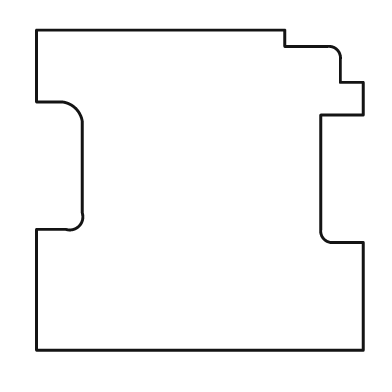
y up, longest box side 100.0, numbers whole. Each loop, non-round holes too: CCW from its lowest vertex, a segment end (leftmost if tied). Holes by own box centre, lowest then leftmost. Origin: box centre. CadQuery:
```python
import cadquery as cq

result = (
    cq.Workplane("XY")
    .moveTo(-50.0, -49.0)
    .lineTo(50.0, -49.0)
    .lineTo(50.0, -16.0)
    .lineTo(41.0, -16.0)
    .threePointArc((38.0, -15.0), (37.0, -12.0))
    .lineTo(37.0, 23.0)
    .lineTo(50.0, 23.0)
    .lineTo(50.0, 33.0)
    .lineTo(43.0, 33.0)
    .lineTo(43.0, 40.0)
    .threePointArc((42.0, 43.0), (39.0, 44.0))
    .lineTo(26.0, 44.0)
    .lineTo(26.0, 49.0)
    .lineTo(-50.0, 49.0)
    .lineTo(-50.0, 27.0)
    .lineTo(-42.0, 27.0)
    .threePointArc((-38.0, 25.0), (-36.0, 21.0))
    .lineTo(-36.0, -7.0)
    .threePointArc((-37.0, -11.0), (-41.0, -12.0))
    .lineTo(-50.0, -12.0)
    .close()
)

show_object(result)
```